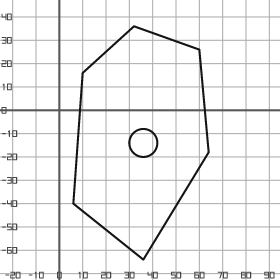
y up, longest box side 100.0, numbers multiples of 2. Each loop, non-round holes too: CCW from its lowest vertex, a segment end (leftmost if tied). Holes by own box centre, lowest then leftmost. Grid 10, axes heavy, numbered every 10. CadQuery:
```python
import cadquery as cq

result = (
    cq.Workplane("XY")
    .moveTo(36.0, -64.0)
    .lineTo(64.0, -18.0)
    .lineTo(60.0, 26.0)
    .lineTo(32.0, 36.0)
    .lineTo(10.0, 16.0)
    .lineTo(6.0, -40.0)
    .close()
    .moveTo(36.0, -14.0)
    .circle(6.0)
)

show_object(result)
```